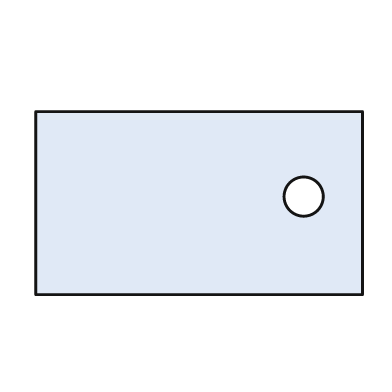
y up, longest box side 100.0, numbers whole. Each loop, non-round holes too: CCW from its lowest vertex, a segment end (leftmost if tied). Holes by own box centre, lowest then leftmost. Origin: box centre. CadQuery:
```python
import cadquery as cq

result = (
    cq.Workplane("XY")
    .moveTo(-50.0, -28.0)
    .lineTo(50.0, -28.0)
    .lineTo(50.0, 28.0)
    .lineTo(-50.0, 28.0)
    .close()
    .moveTo(32.0, 2.0)
    .circle(6.0)
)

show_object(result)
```